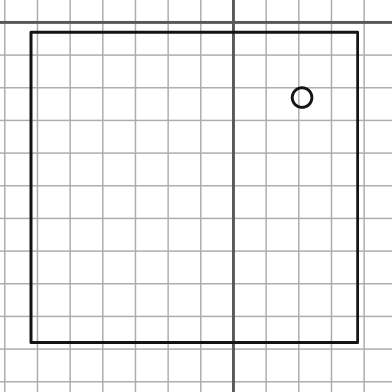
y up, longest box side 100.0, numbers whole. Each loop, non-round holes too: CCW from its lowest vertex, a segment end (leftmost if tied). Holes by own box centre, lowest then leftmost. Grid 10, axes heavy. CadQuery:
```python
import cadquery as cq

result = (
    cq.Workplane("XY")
    .moveTo(-62.0, -98.0)
    .lineTo(38.0, -98.0)
    .lineTo(38.0, -3.0)
    .lineTo(-62.0, -3.0)
    .close()
    .moveTo(21.0, -23.0)
    .circle(3.0)
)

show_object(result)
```